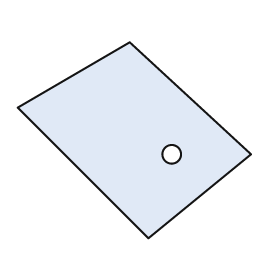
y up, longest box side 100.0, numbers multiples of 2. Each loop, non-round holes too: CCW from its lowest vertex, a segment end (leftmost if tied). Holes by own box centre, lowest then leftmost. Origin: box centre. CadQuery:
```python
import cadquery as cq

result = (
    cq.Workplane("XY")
    .moveTo(6.0, -42.0)
    .lineTo(50.0, -6.0)
    .lineTo(-2.0, 42.0)
    .lineTo(-50.0, 14.0)
    .close()
    .moveTo(16.0, -6.0)
    .circle(4.0)
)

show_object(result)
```